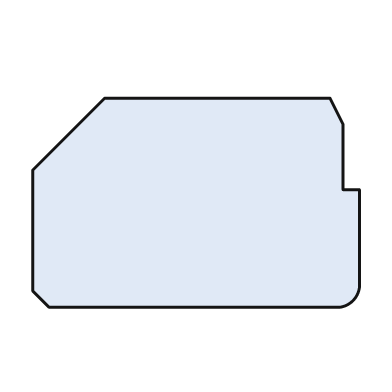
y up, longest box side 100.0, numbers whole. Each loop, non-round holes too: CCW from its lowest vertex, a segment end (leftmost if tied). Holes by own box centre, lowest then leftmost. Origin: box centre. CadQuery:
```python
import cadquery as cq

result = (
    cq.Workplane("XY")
    .moveTo(-45.0, -32.0)
    .lineTo(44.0, -32.0)
    .threePointArc((48.0, -30.0), (50.0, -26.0))
    .lineTo(50.0, 4.0)
    .lineTo(45.0, 4.0)
    .lineTo(45.0, 24.0)
    .lineTo(41.0, 32.0)
    .lineTo(-28.0, 32.0)
    .lineTo(-50.0, 10.0)
    .lineTo(-50.0, -27.0)
    .close()
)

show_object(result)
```